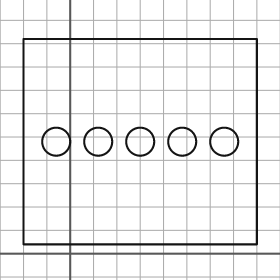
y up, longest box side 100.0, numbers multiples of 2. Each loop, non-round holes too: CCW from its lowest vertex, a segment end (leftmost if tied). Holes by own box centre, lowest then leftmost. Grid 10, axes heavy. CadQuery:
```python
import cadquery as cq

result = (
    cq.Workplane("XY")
    .moveTo(-20.0, 4.0)
    .lineTo(80.0, 4.0)
    .lineTo(80.0, 92.0)
    .lineTo(-20.0, 92.0)
    .close()
    .moveTo(-6.0, 48.0)
    .circle(6.0)
    .moveTo(12.0, 48.0)
    .circle(6.0)
    .moveTo(30.0, 48.0)
    .circle(6.0)
    .moveTo(48.0, 48.0)
    .circle(6.0)
    .moveTo(66.0, 48.0)
    .circle(6.0)
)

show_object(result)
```